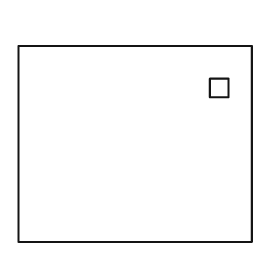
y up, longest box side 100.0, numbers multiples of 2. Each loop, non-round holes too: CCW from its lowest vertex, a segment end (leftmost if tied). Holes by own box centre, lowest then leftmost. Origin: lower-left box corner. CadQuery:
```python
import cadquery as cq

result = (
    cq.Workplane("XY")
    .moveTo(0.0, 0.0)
    .lineTo(100.0, 0.0)
    .lineTo(100.0, 84.0)
    .lineTo(0.0, 84.0)
    .close()
    .moveTo(82.0, 62.0)
    .lineTo(90.0, 62.0)
    .lineTo(90.0, 70.0)
    .lineTo(82.0, 70.0)
    .close()
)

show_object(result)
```